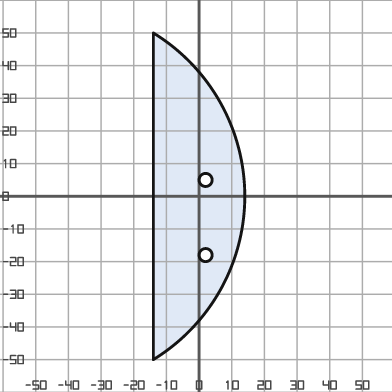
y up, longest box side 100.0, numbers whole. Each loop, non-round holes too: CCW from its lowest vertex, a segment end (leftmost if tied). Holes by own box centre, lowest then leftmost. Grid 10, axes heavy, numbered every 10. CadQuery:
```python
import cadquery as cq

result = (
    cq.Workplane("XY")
    .moveTo(-14.0, -50.0)
    .threePointArc((14.0, 0.0), (-14.0, 50.0))
    .close()
    .moveTo(2.0, -18.0)
    .circle(2.0)
    .moveTo(2.0, 5.0)
    .circle(2.0)
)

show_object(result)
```